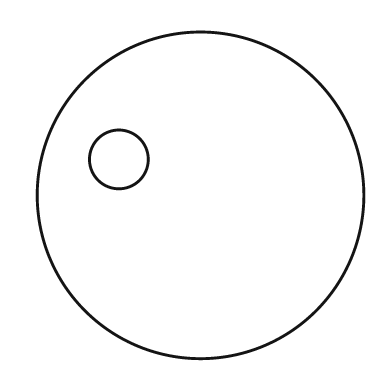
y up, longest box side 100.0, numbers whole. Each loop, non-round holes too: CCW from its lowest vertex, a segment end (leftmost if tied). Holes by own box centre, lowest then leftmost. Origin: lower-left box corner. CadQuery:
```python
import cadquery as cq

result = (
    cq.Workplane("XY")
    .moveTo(50.0, 50.0)
    .circle(50.0)
    .moveTo(25.0, 61.0)
    .circle(9.0)
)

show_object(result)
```